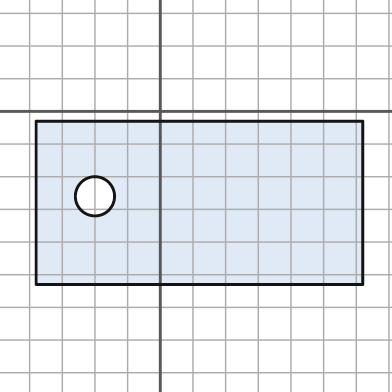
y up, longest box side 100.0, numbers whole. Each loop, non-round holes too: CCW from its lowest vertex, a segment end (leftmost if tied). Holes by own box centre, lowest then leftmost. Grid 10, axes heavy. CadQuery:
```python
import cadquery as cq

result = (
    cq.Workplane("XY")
    .moveTo(-38.0, -53.0)
    .lineTo(62.0, -53.0)
    .lineTo(62.0, -3.0)
    .lineTo(-38.0, -3.0)
    .close()
    .moveTo(-20.0, -26.0)
    .circle(6.0)
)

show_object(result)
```